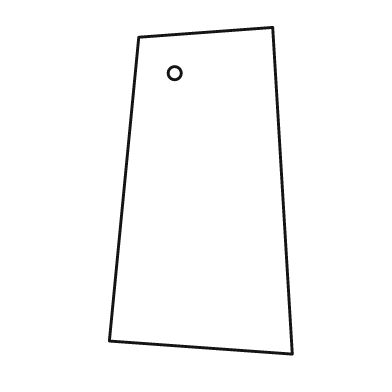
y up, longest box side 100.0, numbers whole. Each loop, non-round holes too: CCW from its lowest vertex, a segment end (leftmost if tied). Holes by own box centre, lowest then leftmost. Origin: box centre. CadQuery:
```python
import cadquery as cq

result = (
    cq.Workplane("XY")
    .moveTo(28.0, -50.0)
    .lineTo(22.0, 50.0)
    .lineTo(-19.0, 47.0)
    .lineTo(-28.0, -46.0)
    .close()
    .moveTo(-8.0, 36.0)
    .circle(2.0)
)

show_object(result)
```